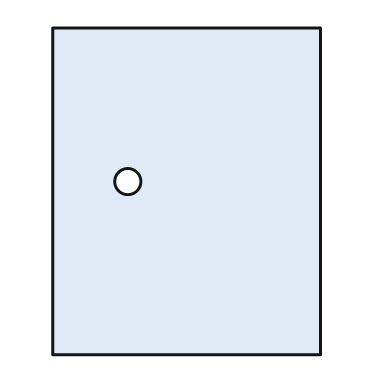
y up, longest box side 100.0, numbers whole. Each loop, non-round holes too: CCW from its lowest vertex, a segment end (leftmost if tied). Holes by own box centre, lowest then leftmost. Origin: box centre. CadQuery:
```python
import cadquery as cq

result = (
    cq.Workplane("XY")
    .moveTo(-41.0, -50.0)
    .lineTo(41.0, -50.0)
    .lineTo(41.0, 50.0)
    .lineTo(-41.0, 50.0)
    .close()
    .moveTo(-18.0, 3.0)
    .circle(4.0)
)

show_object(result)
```